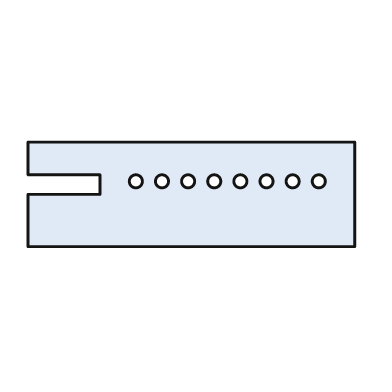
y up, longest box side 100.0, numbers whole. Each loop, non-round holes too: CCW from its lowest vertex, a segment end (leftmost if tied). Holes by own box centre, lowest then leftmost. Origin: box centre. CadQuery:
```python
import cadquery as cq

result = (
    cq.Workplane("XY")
    .moveTo(-50.0, -16.0)
    .lineTo(50.0, -16.0)
    .lineTo(50.0, 16.0)
    .lineTo(-50.0, 16.0)
    .lineTo(-50.0, 6.0)
    .lineTo(-28.0, 6.0)
    .lineTo(-28.0, 0.0)
    .lineTo(-50.0, 0.0)
    .close()
    .moveTo(-17.0, 4.0)
    .circle(2.0)
    .moveTo(-9.0, 4.0)
    .circle(2.0)
    .moveTo(-1.0, 4.0)
    .circle(2.0)
    .moveTo(7.0, 4.0)
    .circle(2.0)
    .moveTo(15.0, 4.0)
    .circle(2.0)
    .moveTo(23.0, 4.0)
    .circle(2.0)
    .moveTo(31.0, 4.0)
    .circle(2.0)
    .moveTo(39.0, 4.0)
    .circle(2.0)
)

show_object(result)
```